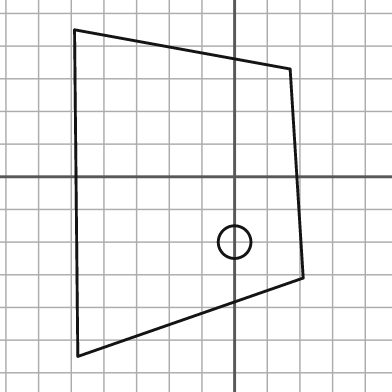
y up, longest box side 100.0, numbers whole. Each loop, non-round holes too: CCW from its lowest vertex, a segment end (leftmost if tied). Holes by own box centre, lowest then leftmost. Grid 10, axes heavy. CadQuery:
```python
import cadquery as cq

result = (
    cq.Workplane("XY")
    .moveTo(-48.0, -55.0)
    .lineTo(21.0, -31.0)
    .lineTo(17.0, 33.0)
    .lineTo(-49.0, 45.0)
    .close()
    .moveTo(0.0, -20.0)
    .circle(5.0)
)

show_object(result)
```